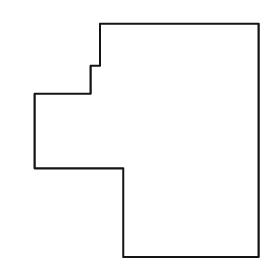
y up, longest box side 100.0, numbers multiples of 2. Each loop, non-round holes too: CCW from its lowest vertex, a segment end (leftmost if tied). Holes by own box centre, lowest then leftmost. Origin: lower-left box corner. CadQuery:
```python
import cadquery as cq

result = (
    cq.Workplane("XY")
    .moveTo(38.0, 0.0)
    .lineTo(96.0, 0.0)
    .lineTo(96.0, 100.0)
    .lineTo(28.0, 100.0)
    .lineTo(28.0, 82.0)
    .lineTo(24.0, 82.0)
    .lineTo(24.0, 70.0)
    .lineTo(0.0, 70.0)
    .lineTo(0.0, 38.0)
    .lineTo(38.0, 38.0)
    .close()
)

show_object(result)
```